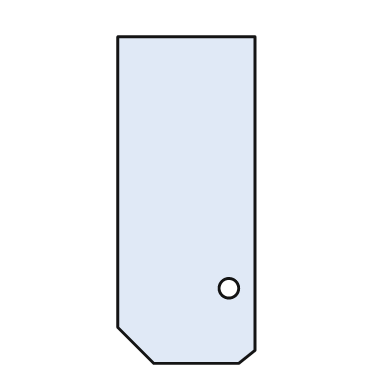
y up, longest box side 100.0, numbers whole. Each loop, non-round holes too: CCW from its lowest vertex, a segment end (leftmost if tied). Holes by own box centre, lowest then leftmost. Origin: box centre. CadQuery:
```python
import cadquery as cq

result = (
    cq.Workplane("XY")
    .moveTo(-10.0, -50.0)
    .lineTo(16.0, -50.0)
    .lineTo(21.0, -46.0)
    .lineTo(21.0, 50.0)
    .lineTo(-21.0, 50.0)
    .lineTo(-21.0, -39.0)
    .close()
    .moveTo(13.0, -27.0)
    .circle(3.0)
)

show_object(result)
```